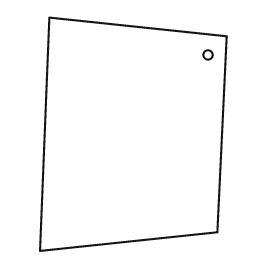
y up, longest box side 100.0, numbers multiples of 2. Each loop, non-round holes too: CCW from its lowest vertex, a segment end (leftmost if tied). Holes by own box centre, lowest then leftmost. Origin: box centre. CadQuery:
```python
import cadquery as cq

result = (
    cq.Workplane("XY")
    .moveTo(-40.0, -50.0)
    .lineTo(36.0, -42.0)
    .lineTo(40.0, 42.0)
    .lineTo(-36.0, 50.0)
    .close()
    .moveTo(32.0, 34.0)
    .circle(2.0)
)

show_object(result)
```